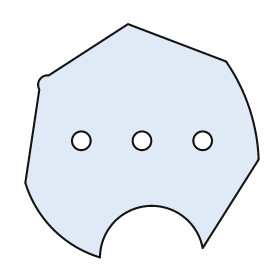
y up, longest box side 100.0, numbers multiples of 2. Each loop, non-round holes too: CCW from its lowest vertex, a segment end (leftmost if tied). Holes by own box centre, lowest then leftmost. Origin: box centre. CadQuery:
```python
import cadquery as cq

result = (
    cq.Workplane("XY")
    .moveTo(-18.0, -50.0)
    .threePointArc((2.0, -28.0), (26.0, -46.0))
    .lineTo(50.0, -8.0)
    .threePointArc((46.0, 14.0), (36.0, 34.0))
    .lineTo(-6.0, 50.0)
    .lineTo(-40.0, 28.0)
    .threePointArc((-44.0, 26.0), (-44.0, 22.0))
    .lineTo(-50.0, -18.0)
    .threePointArc((-38.0, -38.0), (-18.0, -50.0))
    .close()
    .moveTo(-26.0, 0.0)
    .circle(4.0)
    .moveTo(0.0, 0.0)
    .circle(4.0)
    .moveTo(26.0, 0.0)
    .circle(4.0)
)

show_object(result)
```